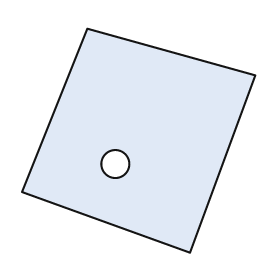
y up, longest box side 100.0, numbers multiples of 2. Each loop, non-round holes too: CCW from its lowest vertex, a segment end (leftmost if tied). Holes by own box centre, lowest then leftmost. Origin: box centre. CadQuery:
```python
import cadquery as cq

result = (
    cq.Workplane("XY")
    .moveTo(22.0, -48.0)
    .lineTo(50.0, 28.0)
    .lineTo(-22.0, 48.0)
    .lineTo(-50.0, -22.0)
    .close()
    .moveTo(-10.0, -10.0)
    .circle(6.0)
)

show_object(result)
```